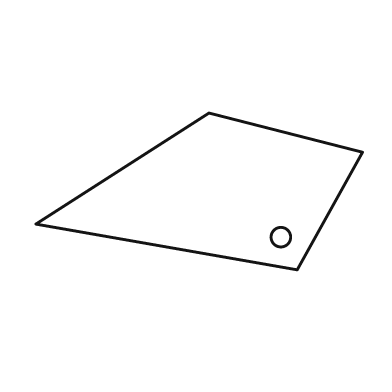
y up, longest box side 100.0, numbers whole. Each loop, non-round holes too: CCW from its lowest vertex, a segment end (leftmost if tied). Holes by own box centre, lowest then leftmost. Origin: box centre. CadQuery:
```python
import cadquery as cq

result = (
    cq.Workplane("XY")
    .moveTo(30.0, -24.0)
    .lineTo(50.0, 12.0)
    .lineTo(3.0, 24.0)
    .lineTo(-50.0, -10.0)
    .close()
    .moveTo(25.0, -14.0)
    .circle(3.0)
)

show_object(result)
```